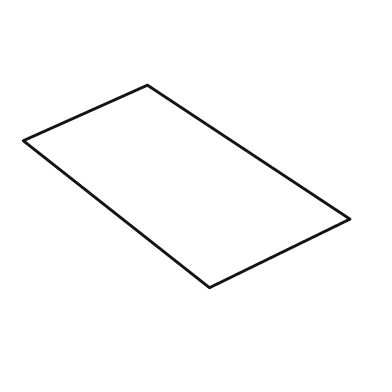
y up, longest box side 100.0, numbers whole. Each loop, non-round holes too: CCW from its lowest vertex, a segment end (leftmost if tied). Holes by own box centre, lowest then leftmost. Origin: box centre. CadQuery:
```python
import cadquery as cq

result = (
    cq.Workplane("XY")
    .moveTo(7.0, -31.0)
    .lineTo(50.0, -10.0)
    .lineTo(-12.0, 31.0)
    .lineTo(-50.0, 14.0)
    .close()
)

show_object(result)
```